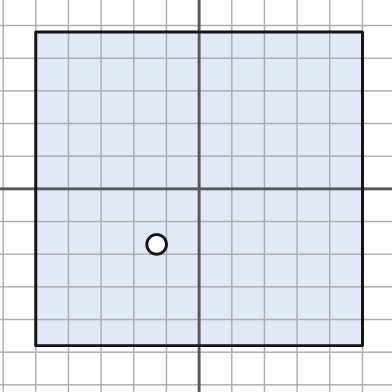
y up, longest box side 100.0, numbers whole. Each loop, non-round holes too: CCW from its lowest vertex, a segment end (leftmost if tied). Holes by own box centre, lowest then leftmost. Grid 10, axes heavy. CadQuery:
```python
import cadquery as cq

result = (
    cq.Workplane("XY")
    .moveTo(-50.0, -48.0)
    .lineTo(50.0, -48.0)
    .lineTo(50.0, 48.0)
    .lineTo(-50.0, 48.0)
    .close()
    .moveTo(-13.0, -17.0)
    .circle(3.0)
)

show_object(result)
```